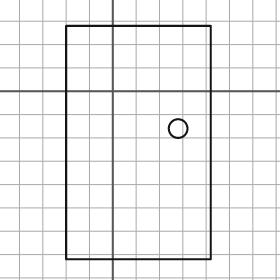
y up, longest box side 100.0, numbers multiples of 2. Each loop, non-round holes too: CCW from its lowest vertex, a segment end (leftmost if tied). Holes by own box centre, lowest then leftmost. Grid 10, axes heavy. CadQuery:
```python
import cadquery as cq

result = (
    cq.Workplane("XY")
    .moveTo(-20.0, -72.0)
    .lineTo(42.0, -72.0)
    .lineTo(42.0, 28.0)
    .lineTo(-20.0, 28.0)
    .close()
    .moveTo(28.0, -16.0)
    .circle(4.0)
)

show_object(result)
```